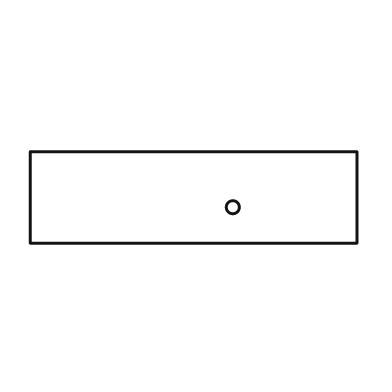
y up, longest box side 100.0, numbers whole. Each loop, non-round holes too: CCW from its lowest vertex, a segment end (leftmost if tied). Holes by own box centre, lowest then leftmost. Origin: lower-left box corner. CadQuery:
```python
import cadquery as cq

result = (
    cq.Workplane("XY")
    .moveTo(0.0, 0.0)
    .lineTo(100.0, 0.0)
    .lineTo(100.0, 28.0)
    .lineTo(0.0, 28.0)
    .close()
    .moveTo(62.0, 11.0)
    .circle(2.0)
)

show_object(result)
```